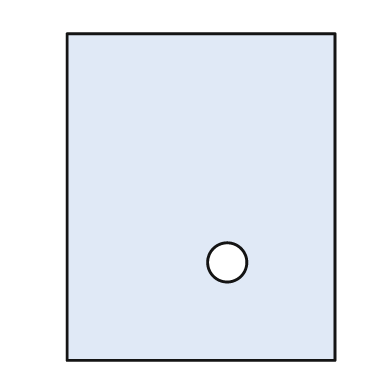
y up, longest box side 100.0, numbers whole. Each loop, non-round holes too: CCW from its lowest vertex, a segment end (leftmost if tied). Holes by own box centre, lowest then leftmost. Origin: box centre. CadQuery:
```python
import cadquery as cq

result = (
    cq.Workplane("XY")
    .moveTo(-41.0, -50.0)
    .lineTo(41.0, -50.0)
    .lineTo(41.0, 50.0)
    .lineTo(-41.0, 50.0)
    .close()
    .moveTo(8.0, -20.0)
    .circle(6.0)
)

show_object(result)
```